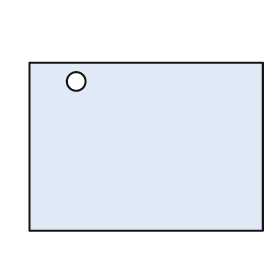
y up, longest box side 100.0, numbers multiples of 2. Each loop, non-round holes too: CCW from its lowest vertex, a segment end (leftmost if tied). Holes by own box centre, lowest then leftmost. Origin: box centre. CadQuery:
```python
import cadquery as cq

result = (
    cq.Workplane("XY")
    .moveTo(-50.0, -36.0)
    .lineTo(50.0, -36.0)
    .lineTo(50.0, 36.0)
    .lineTo(-50.0, 36.0)
    .close()
    .moveTo(-30.0, 28.0)
    .circle(4.0)
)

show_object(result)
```